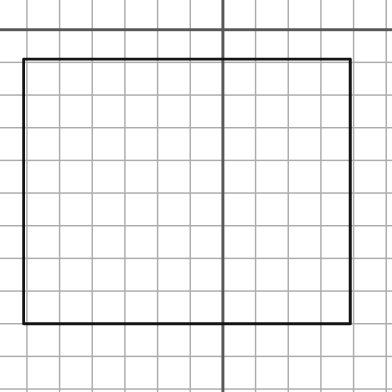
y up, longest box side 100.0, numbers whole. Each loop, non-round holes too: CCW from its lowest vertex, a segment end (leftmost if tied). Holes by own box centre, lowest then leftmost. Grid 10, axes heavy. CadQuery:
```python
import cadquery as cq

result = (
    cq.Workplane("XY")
    .moveTo(-61.0, -90.0)
    .lineTo(39.0, -90.0)
    .lineTo(39.0, -9.0)
    .lineTo(-61.0, -9.0)
    .close()
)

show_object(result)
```